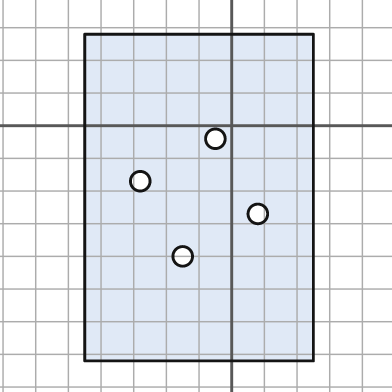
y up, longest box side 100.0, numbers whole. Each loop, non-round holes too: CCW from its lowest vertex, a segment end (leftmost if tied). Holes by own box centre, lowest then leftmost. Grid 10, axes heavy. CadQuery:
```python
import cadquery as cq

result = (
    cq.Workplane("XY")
    .moveTo(-45.0, -72.0)
    .lineTo(25.0, -72.0)
    .lineTo(25.0, 28.0)
    .lineTo(-45.0, 28.0)
    .close()
    .moveTo(-15.0, -40.0)
    .circle(3.0)
    .moveTo(8.0, -27.0)
    .circle(3.0)
    .moveTo(-28.0, -17.0)
    .circle(3.0)
    .moveTo(-5.0, -4.0)
    .circle(3.0)
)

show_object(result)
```